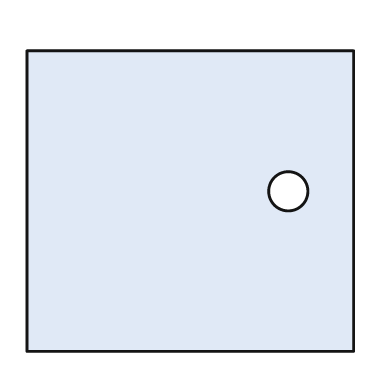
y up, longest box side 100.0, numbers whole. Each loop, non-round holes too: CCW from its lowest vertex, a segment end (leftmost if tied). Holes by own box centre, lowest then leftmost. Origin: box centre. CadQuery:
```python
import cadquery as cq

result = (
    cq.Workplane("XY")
    .moveTo(-50.0, -46.0)
    .lineTo(50.0, -46.0)
    .lineTo(50.0, 46.0)
    .lineTo(-50.0, 46.0)
    .close()
    .moveTo(30.0, 3.0)
    .circle(6.0)
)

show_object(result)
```